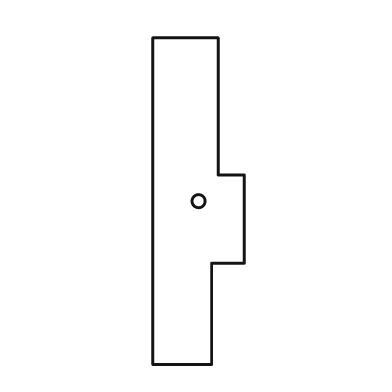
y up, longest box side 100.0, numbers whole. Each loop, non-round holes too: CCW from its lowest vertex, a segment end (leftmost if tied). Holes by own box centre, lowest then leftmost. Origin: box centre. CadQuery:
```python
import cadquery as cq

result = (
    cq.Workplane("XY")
    .moveTo(-14.0, -50.0)
    .lineTo(4.0, -50.0)
    .lineTo(4.0, -19.0)
    .lineTo(14.0, -19.0)
    .lineTo(14.0, 8.0)
    .lineTo(6.0, 8.0)
    .lineTo(6.0, 50.0)
    .lineTo(-14.0, 50.0)
    .close()
    .moveTo(0.0, 0.0)
    .circle(2.0)
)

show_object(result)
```